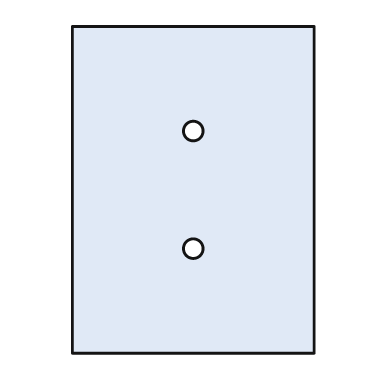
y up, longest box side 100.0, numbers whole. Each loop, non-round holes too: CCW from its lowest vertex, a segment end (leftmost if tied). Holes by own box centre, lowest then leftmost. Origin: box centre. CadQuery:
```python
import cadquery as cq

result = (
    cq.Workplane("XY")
    .moveTo(-37.0, -50.0)
    .lineTo(37.0, -50.0)
    .lineTo(37.0, 50.0)
    .lineTo(-37.0, 50.0)
    .close()
    .moveTo(0.0, -18.0)
    .circle(3.0)
    .moveTo(0.0, 18.0)
    .circle(3.0)
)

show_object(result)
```